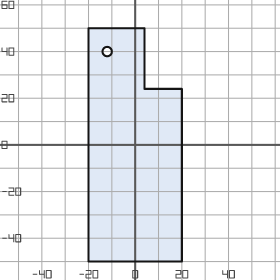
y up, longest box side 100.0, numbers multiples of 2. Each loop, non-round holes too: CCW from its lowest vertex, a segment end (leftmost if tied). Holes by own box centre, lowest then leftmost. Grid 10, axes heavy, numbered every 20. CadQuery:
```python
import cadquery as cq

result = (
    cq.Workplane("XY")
    .moveTo(-20.0, -50.0)
    .lineTo(20.0, -50.0)
    .lineTo(20.0, 24.0)
    .lineTo(4.0, 24.0)
    .lineTo(4.0, 50.0)
    .lineTo(-20.0, 50.0)
    .close()
    .moveTo(-12.0, 40.0)
    .circle(2.0)
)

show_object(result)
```